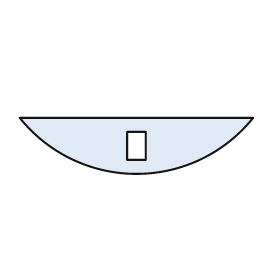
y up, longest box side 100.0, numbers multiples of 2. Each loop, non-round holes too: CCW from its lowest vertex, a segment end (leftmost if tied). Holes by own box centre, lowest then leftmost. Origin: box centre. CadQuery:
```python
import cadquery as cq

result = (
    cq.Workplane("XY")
    .moveTo(-50.0, 12.0)
    .threePointArc((0.0, -12.0), (50.0, 12.0))
    .close()
    .moveTo(-4.0, -6.0)
    .lineTo(4.0, -6.0)
    .lineTo(4.0, 6.0)
    .lineTo(-4.0, 6.0)
    .close()
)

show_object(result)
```